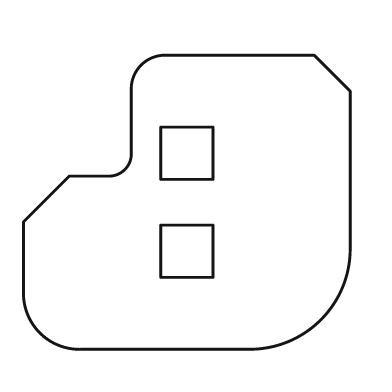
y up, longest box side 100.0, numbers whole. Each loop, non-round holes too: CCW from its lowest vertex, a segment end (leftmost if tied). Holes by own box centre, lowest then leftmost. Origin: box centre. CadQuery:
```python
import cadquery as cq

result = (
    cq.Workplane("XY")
    .moveTo(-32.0, -45.0)
    .lineTo(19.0, -45.0)
    .threePointArc((41.0, -36.0), (50.0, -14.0))
    .lineTo(50.0, 34.0)
    .lineTo(39.0, 45.0)
    .lineTo(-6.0, 45.0)
    .threePointArc((-14.0, 42.0), (-17.0, 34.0))
    .lineTo(-17.0, 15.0)
    .threePointArc((-19.0, 10.0), (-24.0, 8.0))
    .lineTo(-36.0, 8.0)
    .lineTo(-50.0, -6.0)
    .lineTo(-50.0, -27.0)
    .threePointArc((-45.0, -40.0), (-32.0, -45.0))
    .close()
    .moveTo(-8.0, -23.0)
    .lineTo(8.0, -23.0)
    .lineTo(8.0, -7.0)
    .lineTo(-8.0, -7.0)
    .close()
    .moveTo(-8.0, 7.0)
    .lineTo(8.0, 7.0)
    .lineTo(8.0, 23.0)
    .lineTo(-8.0, 23.0)
    .close()
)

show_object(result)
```